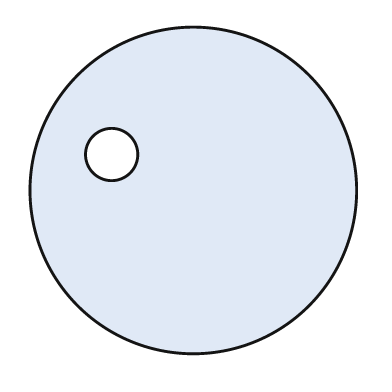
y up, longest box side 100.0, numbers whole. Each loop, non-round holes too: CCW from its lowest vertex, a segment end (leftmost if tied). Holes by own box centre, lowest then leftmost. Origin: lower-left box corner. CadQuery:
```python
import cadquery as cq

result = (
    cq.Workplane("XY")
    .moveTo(50.0, 50.0)
    .circle(50.0)
    .moveTo(25.0, 61.0)
    .circle(8.0)
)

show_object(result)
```